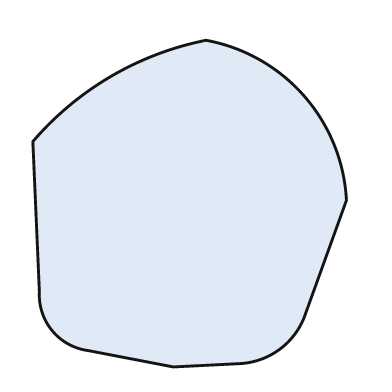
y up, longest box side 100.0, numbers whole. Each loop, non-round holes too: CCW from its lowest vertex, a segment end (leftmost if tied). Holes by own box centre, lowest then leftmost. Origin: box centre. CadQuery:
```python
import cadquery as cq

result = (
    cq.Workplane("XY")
    .moveTo(-5.0, -50.0)
    .lineTo(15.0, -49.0)
    .threePointArc((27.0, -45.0), (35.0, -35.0))
    .lineTo(48.0, 1.0)
    .threePointArc((35.0, 33.0), (5.0, 50.0))
    .threePointArc((-24.0, 39.0), (-48.0, 19.0))
    .lineTo(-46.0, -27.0)
    .threePointArc((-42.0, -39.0), (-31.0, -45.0))
    .close()
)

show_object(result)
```